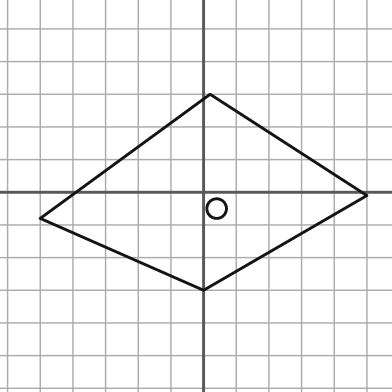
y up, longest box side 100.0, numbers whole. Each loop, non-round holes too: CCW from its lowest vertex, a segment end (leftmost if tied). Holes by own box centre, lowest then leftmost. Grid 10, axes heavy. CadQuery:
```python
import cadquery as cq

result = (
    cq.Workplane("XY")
    .moveTo(0.0, -30.0)
    .lineTo(50.0, -1.0)
    .lineTo(2.0, 30.0)
    .lineTo(-50.0, -8.0)
    .close()
    .moveTo(4.0, -5.0)
    .circle(3.0)
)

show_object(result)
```